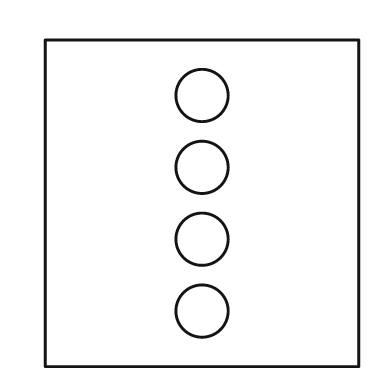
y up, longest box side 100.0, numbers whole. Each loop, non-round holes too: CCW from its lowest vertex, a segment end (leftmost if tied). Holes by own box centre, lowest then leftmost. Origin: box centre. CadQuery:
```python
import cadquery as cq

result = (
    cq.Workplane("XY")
    .moveTo(-48.0, -50.0)
    .lineTo(48.0, -50.0)
    .lineTo(48.0, 50.0)
    .lineTo(-48.0, 50.0)
    .close()
    .moveTo(0.0, -33.0)
    .circle(8.0)
    .moveTo(0.0, -11.0)
    .circle(8.0)
    .moveTo(0.0, 11.0)
    .circle(8.0)
    .moveTo(0.0, 33.0)
    .circle(8.0)
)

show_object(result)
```